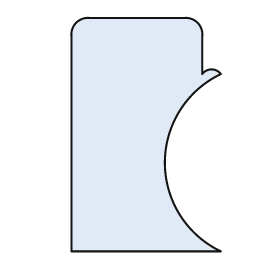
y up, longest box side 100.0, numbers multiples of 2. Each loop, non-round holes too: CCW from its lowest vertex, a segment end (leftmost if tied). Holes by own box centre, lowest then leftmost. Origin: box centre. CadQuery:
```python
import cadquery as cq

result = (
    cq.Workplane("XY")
    .moveTo(-32.0, -50.0)
    .lineTo(32.0, -50.0)
    .threePointArc((8.0, -12.0), (32.0, 26.0))
    .threePointArc((28.0, 28.0), (24.0, 26.0))
    .lineTo(24.0, 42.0)
    .threePointArc((22.0, 48.0), (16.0, 50.0))
    .lineTo(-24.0, 50.0)
    .threePointArc((-30.0, 48.0), (-32.0, 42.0))
    .close()
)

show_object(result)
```